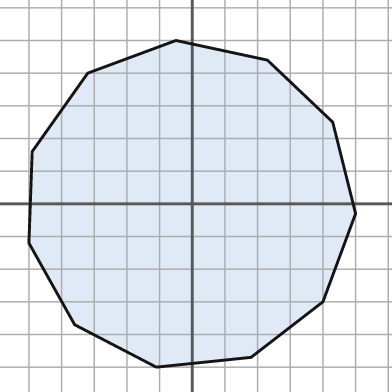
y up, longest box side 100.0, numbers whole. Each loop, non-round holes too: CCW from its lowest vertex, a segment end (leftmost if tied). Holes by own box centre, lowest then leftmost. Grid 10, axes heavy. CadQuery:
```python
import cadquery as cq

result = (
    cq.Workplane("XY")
    .moveTo(-11.0, -50.0)
    .lineTo(18.0, -47.0)
    .lineTo(40.0, -30.0)
    .lineTo(50.0, -3.0)
    .lineTo(43.0, 25.0)
    .lineTo(23.0, 44.0)
    .lineTo(-5.0, 50.0)
    .lineTo(-32.0, 40.0)
    .lineTo(-49.0, 16.0)
    .lineTo(-50.0, -12.0)
    .lineTo(-36.0, -37.0)
    .close()
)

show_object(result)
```